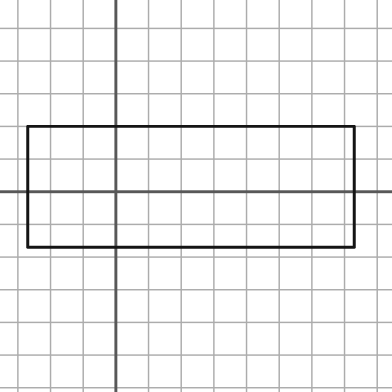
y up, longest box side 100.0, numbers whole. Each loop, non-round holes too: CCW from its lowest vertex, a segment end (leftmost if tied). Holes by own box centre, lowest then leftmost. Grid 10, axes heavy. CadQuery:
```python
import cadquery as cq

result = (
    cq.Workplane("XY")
    .moveTo(-27.0, -17.0)
    .lineTo(73.0, -17.0)
    .lineTo(73.0, 20.0)
    .lineTo(-27.0, 20.0)
    .close()
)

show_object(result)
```